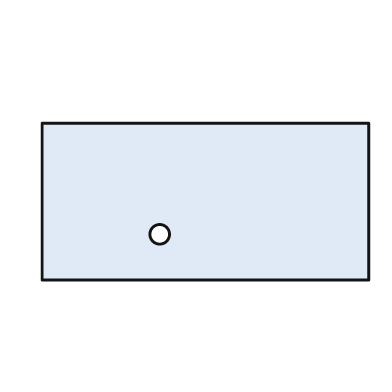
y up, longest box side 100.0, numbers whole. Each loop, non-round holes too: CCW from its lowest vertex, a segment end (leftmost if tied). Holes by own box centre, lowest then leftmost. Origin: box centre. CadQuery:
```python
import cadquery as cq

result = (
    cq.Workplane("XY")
    .moveTo(-50.0, -24.0)
    .lineTo(50.0, -24.0)
    .lineTo(50.0, 24.0)
    .lineTo(-50.0, 24.0)
    .close()
    .moveTo(-14.0, -10.0)
    .circle(3.0)
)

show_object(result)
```